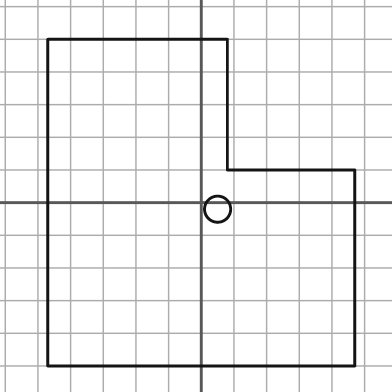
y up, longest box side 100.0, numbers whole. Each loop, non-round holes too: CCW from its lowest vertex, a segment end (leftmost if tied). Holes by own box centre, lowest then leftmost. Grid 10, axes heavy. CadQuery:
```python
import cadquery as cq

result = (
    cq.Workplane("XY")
    .moveTo(-47.0, -50.0)
    .lineTo(47.0, -50.0)
    .lineTo(47.0, 10.0)
    .lineTo(8.0, 10.0)
    .lineTo(8.0, 50.0)
    .lineTo(-47.0, 50.0)
    .close()
    .moveTo(5.0, -2.0)
    .circle(4.0)
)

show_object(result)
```